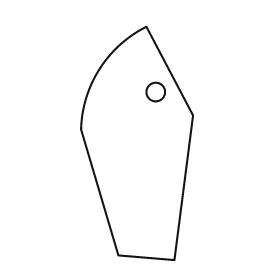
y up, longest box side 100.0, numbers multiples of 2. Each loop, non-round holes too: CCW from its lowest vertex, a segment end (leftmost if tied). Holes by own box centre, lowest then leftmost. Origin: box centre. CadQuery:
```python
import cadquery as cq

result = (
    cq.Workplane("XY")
    .moveTo(16.0, -50.0)
    .lineTo(24.0, 12.0)
    .lineTo(4.0, 50.0)
    .threePointArc((-16.0, 32.0), (-24.0, 6.0))
    .lineTo(-8.0, -48.0)
    .close()
    .moveTo(8.0, 22.0)
    .circle(4.0)
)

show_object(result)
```